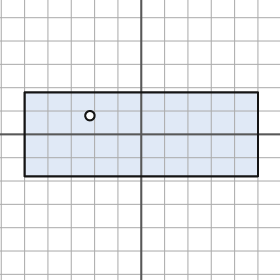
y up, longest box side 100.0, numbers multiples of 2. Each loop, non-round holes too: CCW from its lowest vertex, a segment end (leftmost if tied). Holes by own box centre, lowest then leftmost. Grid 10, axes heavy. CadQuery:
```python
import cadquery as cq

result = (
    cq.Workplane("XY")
    .moveTo(-50.0, -18.0)
    .lineTo(50.0, -18.0)
    .lineTo(50.0, 18.0)
    .lineTo(-50.0, 18.0)
    .close()
    .moveTo(-22.0, 8.0)
    .circle(2.0)
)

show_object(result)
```